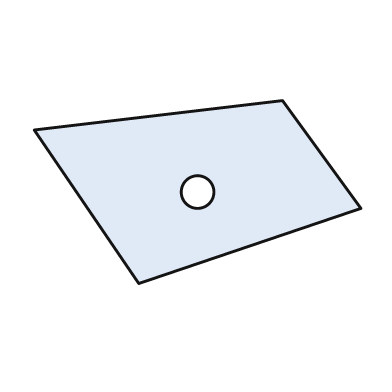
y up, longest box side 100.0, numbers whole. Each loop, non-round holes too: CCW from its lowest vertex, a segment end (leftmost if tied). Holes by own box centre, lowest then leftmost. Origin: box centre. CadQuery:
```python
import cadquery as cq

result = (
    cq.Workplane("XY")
    .moveTo(-18.0, -28.0)
    .lineTo(50.0, -5.0)
    .lineTo(26.0, 28.0)
    .lineTo(-50.0, 19.0)
    .close()
    .moveTo(0.0, 0.0)
    .circle(5.0)
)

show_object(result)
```